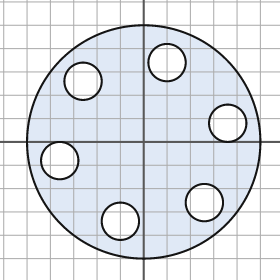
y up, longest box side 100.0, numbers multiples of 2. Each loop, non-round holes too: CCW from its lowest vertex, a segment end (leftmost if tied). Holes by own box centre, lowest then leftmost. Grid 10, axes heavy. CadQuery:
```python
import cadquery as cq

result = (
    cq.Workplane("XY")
    .moveTo(0.0, 0.0)
    .circle(50.0)
    .moveTo(-10.0, -34.0)
    .circle(8.0)
    .moveTo(26.0, -26.0)
    .circle(8.0)
    .moveTo(-36.0, -8.0)
    .circle(8.0)
    .moveTo(36.0, 8.0)
    .circle(8.0)
    .moveTo(-26.0, 26.0)
    .circle(8.0)
    .moveTo(10.0, 34.0)
    .circle(8.0)
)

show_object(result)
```